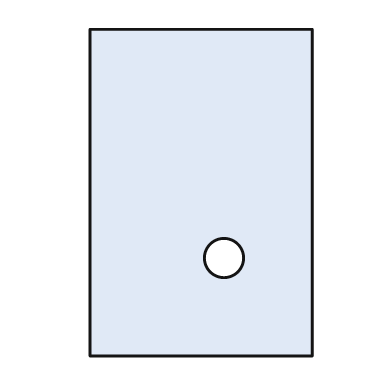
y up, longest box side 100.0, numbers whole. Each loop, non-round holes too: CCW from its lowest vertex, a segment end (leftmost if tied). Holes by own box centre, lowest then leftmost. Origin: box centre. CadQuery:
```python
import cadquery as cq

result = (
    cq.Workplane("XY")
    .moveTo(-34.0, -50.0)
    .lineTo(34.0, -50.0)
    .lineTo(34.0, 50.0)
    .lineTo(-34.0, 50.0)
    .close()
    .moveTo(7.0, -20.0)
    .circle(6.0)
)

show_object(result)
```